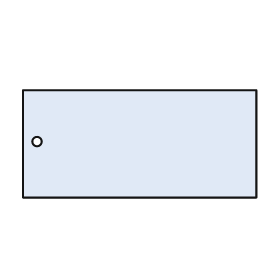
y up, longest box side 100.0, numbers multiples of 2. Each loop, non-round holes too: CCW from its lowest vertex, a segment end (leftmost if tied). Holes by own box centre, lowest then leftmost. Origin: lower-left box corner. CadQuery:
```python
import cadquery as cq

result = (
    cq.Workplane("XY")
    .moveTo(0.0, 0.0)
    .lineTo(100.0, 0.0)
    .lineTo(100.0, 46.0)
    .lineTo(0.0, 46.0)
    .close()
    .moveTo(6.0, 24.0)
    .circle(2.0)
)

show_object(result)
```